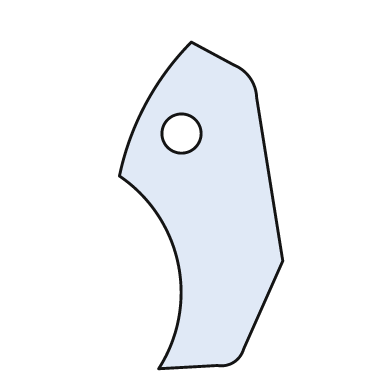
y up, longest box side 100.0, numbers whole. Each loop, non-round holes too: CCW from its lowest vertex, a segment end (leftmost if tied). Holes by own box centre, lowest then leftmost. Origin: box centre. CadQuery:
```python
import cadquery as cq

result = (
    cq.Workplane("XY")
    .moveTo(-13.0, -50.0)
    .lineTo(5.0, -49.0)
    .threePointArc((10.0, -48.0), (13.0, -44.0))
    .lineTo(25.0, -17.0)
    .lineTo(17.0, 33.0)
    .threePointArc((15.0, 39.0), (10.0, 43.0))
    .lineTo(-3.0, 50.0)
    .threePointArc((-17.0, 31.0), (-25.0, 9.0))
    .threePointArc((-7.0, -18.0), (-13.0, -50.0))
    .close()
    .moveTo(-6.0, 22.0)
    .circle(6.0)
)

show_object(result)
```